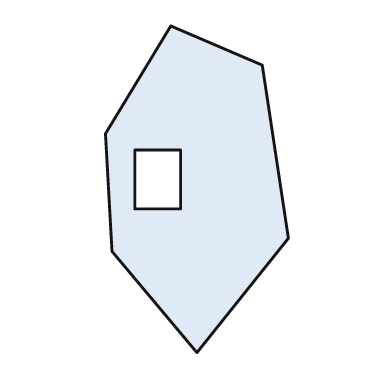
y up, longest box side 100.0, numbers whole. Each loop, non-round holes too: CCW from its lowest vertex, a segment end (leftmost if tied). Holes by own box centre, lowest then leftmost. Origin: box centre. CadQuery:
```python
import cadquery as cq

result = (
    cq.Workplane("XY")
    .moveTo(0.0, -50.0)
    .lineTo(28.0, -15.0)
    .lineTo(20.0, 38.0)
    .lineTo(-8.0, 50.0)
    .lineTo(-28.0, 17.0)
    .lineTo(-26.0, -19.0)
    .close()
    .moveTo(-19.0, -6.0)
    .lineTo(-5.0, -6.0)
    .lineTo(-5.0, 12.0)
    .lineTo(-19.0, 12.0)
    .close()
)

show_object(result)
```